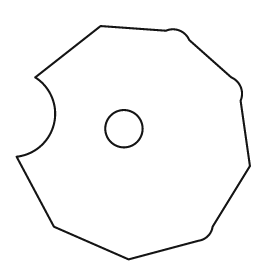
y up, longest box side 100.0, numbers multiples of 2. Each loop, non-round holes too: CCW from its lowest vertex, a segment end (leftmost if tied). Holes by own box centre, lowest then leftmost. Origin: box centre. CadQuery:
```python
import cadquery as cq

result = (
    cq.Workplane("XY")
    .moveTo(-2.0, -50.0)
    .lineTo(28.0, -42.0)
    .threePointArc((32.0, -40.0), (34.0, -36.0))
    .lineTo(50.0, -10.0)
    .lineTo(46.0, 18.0)
    .threePointArc((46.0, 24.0), (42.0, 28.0))
    .lineTo(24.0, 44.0)
    .threePointArc((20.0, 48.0), (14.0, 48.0))
    .lineTo(-14.0, 50.0)
    .lineTo(-42.0, 28.0)
    .threePointArc((-34.0, 8.0), (-50.0, -6.0))
    .lineTo(-34.0, -36.0)
    .close()
    .moveTo(-4.0, 6.0)
    .circle(8.0)
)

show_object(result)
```